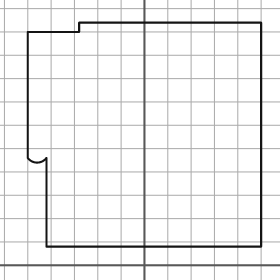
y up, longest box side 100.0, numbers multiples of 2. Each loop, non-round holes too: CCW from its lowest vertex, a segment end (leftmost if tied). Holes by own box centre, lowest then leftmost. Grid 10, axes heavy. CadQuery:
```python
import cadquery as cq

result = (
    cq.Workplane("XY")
    .moveTo(-42.0, 8.0)
    .lineTo(50.0, 8.0)
    .lineTo(50.0, 104.0)
    .lineTo(-28.0, 104.0)
    .lineTo(-28.0, 100.0)
    .lineTo(-50.0, 100.0)
    .lineTo(-50.0, 46.0)
    .threePointArc((-46.0, 44.0), (-42.0, 46.0))
    .close()
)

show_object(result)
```